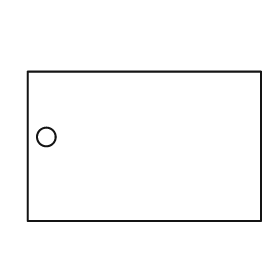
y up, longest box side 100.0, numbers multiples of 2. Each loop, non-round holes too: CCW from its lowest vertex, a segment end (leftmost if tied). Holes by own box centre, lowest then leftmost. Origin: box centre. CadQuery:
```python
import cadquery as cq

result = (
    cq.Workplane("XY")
    .moveTo(-50.0, -32.0)
    .lineTo(50.0, -32.0)
    .lineTo(50.0, 32.0)
    .lineTo(-50.0, 32.0)
    .close()
    .moveTo(-42.0, 4.0)
    .circle(4.0)
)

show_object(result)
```